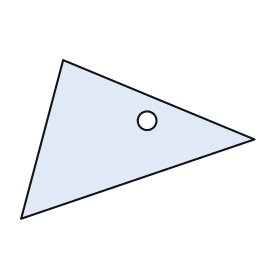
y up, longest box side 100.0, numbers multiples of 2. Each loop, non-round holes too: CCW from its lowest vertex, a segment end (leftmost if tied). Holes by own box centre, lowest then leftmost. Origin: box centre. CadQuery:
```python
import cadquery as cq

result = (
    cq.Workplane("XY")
    .moveTo(-50.0, -34.0)
    .lineTo(50.0, 0.0)
    .lineTo(-32.0, 34.0)
    .close()
    .moveTo(4.0, 8.0)
    .circle(4.0)
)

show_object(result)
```